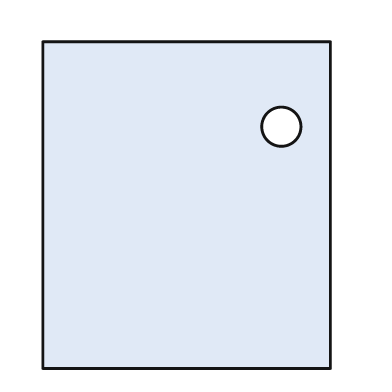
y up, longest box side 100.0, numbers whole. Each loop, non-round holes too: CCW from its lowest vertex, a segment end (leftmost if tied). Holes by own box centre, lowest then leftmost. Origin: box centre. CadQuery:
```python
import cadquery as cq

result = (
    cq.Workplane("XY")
    .moveTo(-44.0, -50.0)
    .lineTo(44.0, -50.0)
    .lineTo(44.0, 50.0)
    .lineTo(-44.0, 50.0)
    .close()
    .moveTo(29.0, 24.0)
    .circle(6.0)
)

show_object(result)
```